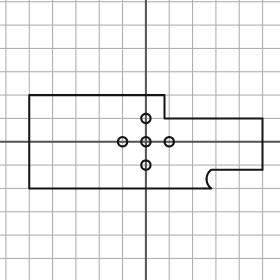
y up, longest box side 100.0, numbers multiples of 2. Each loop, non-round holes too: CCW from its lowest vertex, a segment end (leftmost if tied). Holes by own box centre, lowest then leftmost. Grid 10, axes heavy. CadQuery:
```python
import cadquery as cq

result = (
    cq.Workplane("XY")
    .moveTo(-50.0, -20.0)
    .lineTo(28.0, -20.0)
    .threePointArc((26.0, -16.0), (28.0, -12.0))
    .lineTo(50.0, -12.0)
    .lineTo(50.0, 10.0)
    .lineTo(8.0, 10.0)
    .lineTo(8.0, 20.0)
    .lineTo(-50.0, 20.0)
    .close()
    .moveTo(0.0, -10.0)
    .circle(2.0)
    .moveTo(-10.0, 0.0)
    .circle(2.0)
    .moveTo(0.0, 0.0)
    .circle(2.0)
    .moveTo(10.0, 0.0)
    .circle(2.0)
    .moveTo(0.0, 10.0)
    .circle(2.0)
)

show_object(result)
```